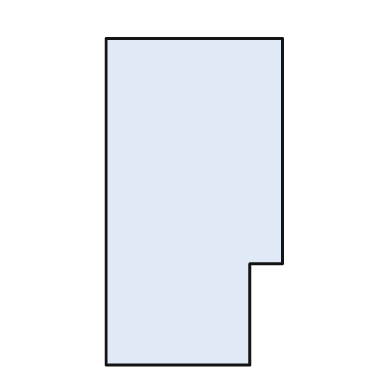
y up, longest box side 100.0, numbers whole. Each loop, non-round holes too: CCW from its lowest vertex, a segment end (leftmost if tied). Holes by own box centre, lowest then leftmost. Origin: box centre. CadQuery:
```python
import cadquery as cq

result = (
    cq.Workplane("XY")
    .moveTo(-27.0, -50.0)
    .lineTo(17.0, -50.0)
    .lineTo(17.0, -19.0)
    .lineTo(27.0, -19.0)
    .lineTo(27.0, 50.0)
    .lineTo(-27.0, 50.0)
    .close()
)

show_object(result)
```